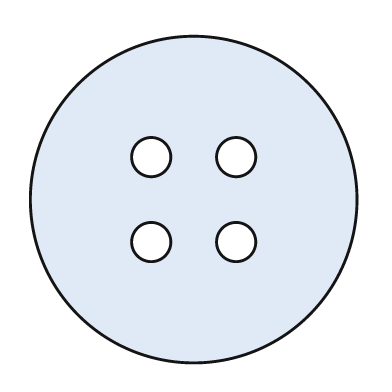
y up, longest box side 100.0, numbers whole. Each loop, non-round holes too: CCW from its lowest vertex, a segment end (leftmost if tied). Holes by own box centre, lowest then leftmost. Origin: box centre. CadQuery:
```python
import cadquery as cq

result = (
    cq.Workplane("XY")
    .moveTo(0.0, 0.0)
    .circle(50.0)
    .moveTo(-13.0, -13.0)
    .circle(6.0)
    .moveTo(13.0, -13.0)
    .circle(6.0)
    .moveTo(-13.0, 13.0)
    .circle(6.0)
    .moveTo(13.0, 13.0)
    .circle(6.0)
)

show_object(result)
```